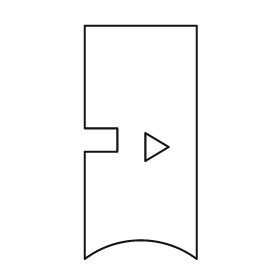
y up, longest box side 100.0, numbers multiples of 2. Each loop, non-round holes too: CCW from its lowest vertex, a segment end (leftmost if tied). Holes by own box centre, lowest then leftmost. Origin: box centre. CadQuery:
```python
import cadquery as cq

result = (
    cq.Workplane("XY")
    .moveTo(-24.0, -50.0)
    .threePointArc((0.0, -42.0), (24.0, -50.0))
    .lineTo(24.0, 50.0)
    .lineTo(-24.0, 50.0)
    .lineTo(-24.0, 6.0)
    .lineTo(-10.0, 6.0)
    .lineTo(-10.0, -4.0)
    .lineTo(-24.0, -4.0)
    .close()
    .moveTo(2.0, -8.0)
    .lineTo(12.0, -2.0)
    .lineTo(2.0, 4.0)
    .close()
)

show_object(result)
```